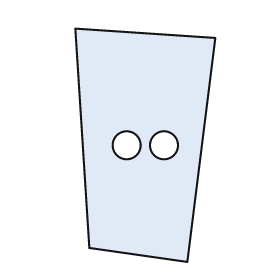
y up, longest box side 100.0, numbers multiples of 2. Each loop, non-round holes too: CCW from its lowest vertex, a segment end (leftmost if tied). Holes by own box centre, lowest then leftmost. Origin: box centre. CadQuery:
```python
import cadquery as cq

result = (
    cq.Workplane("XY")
    .moveTo(18.0, -50.0)
    .lineTo(30.0, 46.0)
    .lineTo(-30.0, 50.0)
    .lineTo(-24.0, -44.0)
    .close()
    .moveTo(-8.0, 0.0)
    .circle(6.0)
    .moveTo(8.0, 0.0)
    .circle(6.0)
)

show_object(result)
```